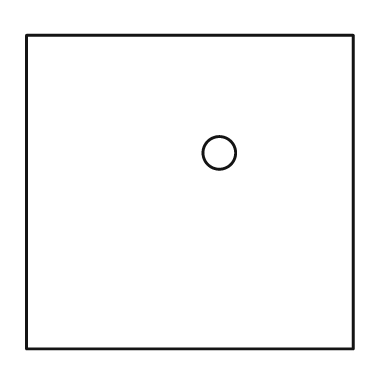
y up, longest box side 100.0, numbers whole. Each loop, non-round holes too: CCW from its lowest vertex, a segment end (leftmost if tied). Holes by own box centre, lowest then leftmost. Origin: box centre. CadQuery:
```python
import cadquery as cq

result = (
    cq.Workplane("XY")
    .moveTo(-50.0, -48.0)
    .lineTo(50.0, -48.0)
    .lineTo(50.0, 48.0)
    .lineTo(-50.0, 48.0)
    .close()
    .moveTo(9.0, 12.0)
    .circle(5.0)
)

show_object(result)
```